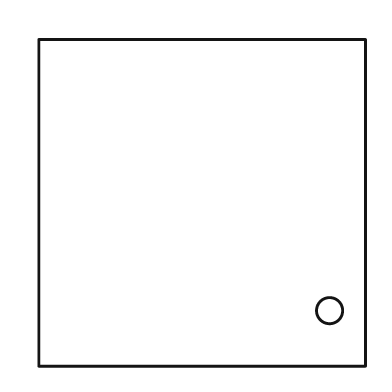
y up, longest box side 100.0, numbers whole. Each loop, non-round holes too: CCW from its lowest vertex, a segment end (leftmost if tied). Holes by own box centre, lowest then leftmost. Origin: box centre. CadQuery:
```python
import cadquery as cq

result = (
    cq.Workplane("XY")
    .moveTo(-50.0, -50.0)
    .lineTo(50.0, -50.0)
    .lineTo(50.0, 50.0)
    .lineTo(-50.0, 50.0)
    .close()
    .moveTo(39.0, -33.0)
    .circle(4.0)
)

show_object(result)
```